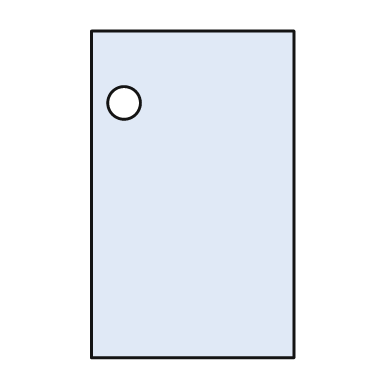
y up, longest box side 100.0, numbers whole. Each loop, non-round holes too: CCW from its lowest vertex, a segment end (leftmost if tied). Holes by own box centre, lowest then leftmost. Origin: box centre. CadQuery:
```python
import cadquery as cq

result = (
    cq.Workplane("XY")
    .moveTo(-31.0, -50.0)
    .lineTo(31.0, -50.0)
    .lineTo(31.0, 50.0)
    .lineTo(-31.0, 50.0)
    .close()
    .moveTo(-21.0, 28.0)
    .circle(5.0)
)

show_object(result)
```